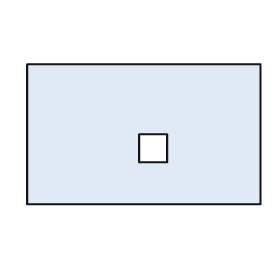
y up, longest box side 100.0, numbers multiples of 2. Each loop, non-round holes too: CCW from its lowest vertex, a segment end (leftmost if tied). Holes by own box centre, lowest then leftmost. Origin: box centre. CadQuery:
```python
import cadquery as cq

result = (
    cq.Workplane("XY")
    .moveTo(-50.0, -30.0)
    .lineTo(50.0, -30.0)
    .lineTo(50.0, 30.0)
    .lineTo(-50.0, 30.0)
    .close()
    .moveTo(-2.0, -12.0)
    .lineTo(10.0, -12.0)
    .lineTo(10.0, 0.0)
    .lineTo(-2.0, 0.0)
    .close()
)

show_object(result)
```